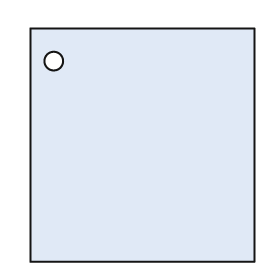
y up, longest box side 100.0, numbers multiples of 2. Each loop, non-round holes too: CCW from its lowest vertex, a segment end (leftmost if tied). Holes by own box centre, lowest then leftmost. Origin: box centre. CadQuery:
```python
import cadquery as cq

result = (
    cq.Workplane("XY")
    .moveTo(-48.0, -50.0)
    .lineTo(48.0, -50.0)
    .lineTo(48.0, 50.0)
    .lineTo(-48.0, 50.0)
    .close()
    .moveTo(-38.0, 36.0)
    .circle(4.0)
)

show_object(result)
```